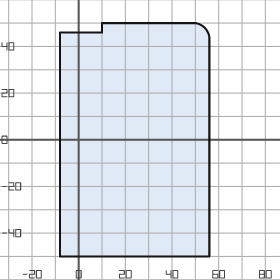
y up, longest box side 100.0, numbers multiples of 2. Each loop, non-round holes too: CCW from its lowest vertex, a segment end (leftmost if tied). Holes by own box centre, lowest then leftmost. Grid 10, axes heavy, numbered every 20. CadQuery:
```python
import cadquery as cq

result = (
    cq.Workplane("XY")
    .moveTo(-8.0, -50.0)
    .lineTo(56.0, -50.0)
    .lineTo(56.0, 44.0)
    .threePointArc((54.0, 48.0), (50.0, 50.0))
    .lineTo(10.0, 50.0)
    .lineTo(10.0, 46.0)
    .lineTo(-8.0, 46.0)
    .close()
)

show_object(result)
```